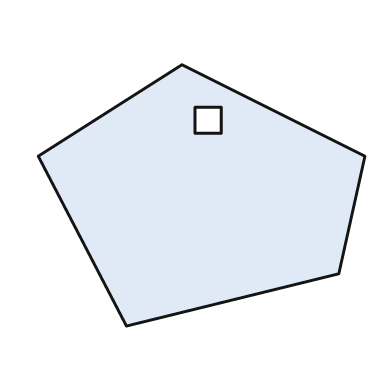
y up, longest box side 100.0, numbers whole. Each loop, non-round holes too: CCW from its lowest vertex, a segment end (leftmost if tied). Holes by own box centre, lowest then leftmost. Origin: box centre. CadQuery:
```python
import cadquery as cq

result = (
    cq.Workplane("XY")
    .moveTo(-23.0, -40.0)
    .lineTo(42.0, -24.0)
    .lineTo(50.0, 12.0)
    .lineTo(-6.0, 40.0)
    .lineTo(-50.0, 12.0)
    .close()
    .moveTo(-2.0, 19.0)
    .lineTo(6.0, 19.0)
    .lineTo(6.0, 27.0)
    .lineTo(-2.0, 27.0)
    .close()
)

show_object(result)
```